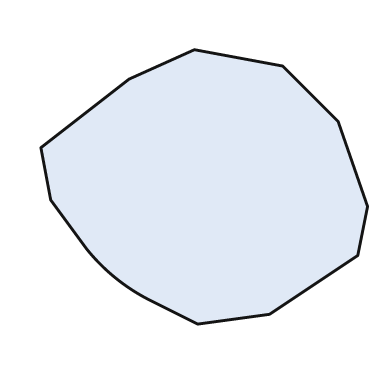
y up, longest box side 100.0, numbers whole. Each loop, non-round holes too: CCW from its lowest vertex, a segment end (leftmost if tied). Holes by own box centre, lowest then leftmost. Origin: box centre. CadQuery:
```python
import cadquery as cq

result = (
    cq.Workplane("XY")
    .moveTo(-2.0, -42.0)
    .lineTo(20.0, -39.0)
    .lineTo(47.0, -21.0)
    .lineTo(50.0, -6.0)
    .lineTo(41.0, 20.0)
    .lineTo(24.0, 37.0)
    .lineTo(-3.0, 42.0)
    .lineTo(-23.0, 33.0)
    .lineTo(-50.0, 12.0)
    .lineTo(-47.0, -4.0)
    .lineTo(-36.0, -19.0)
    .threePointArc((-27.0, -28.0), (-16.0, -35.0))
    .close()
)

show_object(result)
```